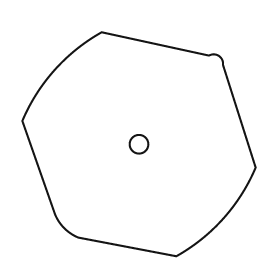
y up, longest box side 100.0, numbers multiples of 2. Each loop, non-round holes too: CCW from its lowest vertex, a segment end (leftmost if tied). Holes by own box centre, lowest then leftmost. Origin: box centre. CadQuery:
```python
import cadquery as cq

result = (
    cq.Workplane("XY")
    .moveTo(16.0, -48.0)
    .threePointArc((36.0, -32.0), (50.0, -10.0))
    .lineTo(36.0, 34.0)
    .threePointArc((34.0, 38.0), (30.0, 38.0))
    .lineTo(-16.0, 48.0)
    .threePointArc((-36.0, 32.0), (-50.0, 10.0))
    .lineTo(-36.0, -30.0)
    .threePointArc((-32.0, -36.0), (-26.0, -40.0))
    .close()
    .moveTo(0.0, 0.0)
    .circle(4.0)
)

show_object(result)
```